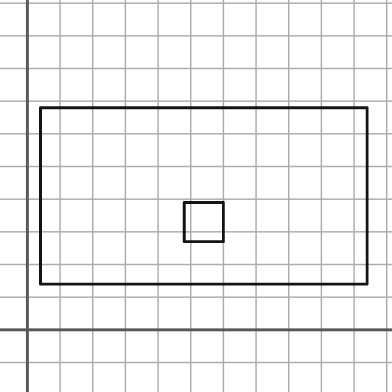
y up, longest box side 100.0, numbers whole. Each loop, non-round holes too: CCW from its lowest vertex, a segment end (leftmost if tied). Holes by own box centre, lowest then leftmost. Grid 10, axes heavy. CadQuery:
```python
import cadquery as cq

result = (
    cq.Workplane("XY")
    .moveTo(4.0, 14.0)
    .lineTo(104.0, 14.0)
    .lineTo(104.0, 68.0)
    .lineTo(4.0, 68.0)
    .close()
    .moveTo(48.0, 27.0)
    .lineTo(60.0, 27.0)
    .lineTo(60.0, 39.0)
    .lineTo(48.0, 39.0)
    .close()
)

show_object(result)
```